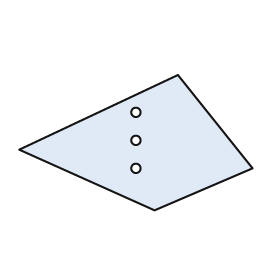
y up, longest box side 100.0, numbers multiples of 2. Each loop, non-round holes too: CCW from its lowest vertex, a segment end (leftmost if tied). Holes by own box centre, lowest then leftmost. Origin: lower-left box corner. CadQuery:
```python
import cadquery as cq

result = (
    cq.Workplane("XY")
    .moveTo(58.0, 0.0)
    .lineTo(100.0, 18.0)
    .lineTo(68.0, 58.0)
    .lineTo(0.0, 26.0)
    .close()
    .moveTo(50.0, 18.0)
    .circle(2.0)
    .moveTo(50.0, 30.0)
    .circle(2.0)
    .moveTo(50.0, 42.0)
    .circle(2.0)
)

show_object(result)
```